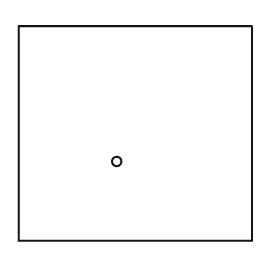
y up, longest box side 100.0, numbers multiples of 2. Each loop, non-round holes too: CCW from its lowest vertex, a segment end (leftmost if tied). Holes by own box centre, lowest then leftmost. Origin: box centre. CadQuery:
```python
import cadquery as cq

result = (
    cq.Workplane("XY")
    .moveTo(-50.0, -46.0)
    .lineTo(50.0, -46.0)
    .lineTo(50.0, 46.0)
    .lineTo(-50.0, 46.0)
    .close()
    .moveTo(-8.0, -12.0)
    .circle(2.0)
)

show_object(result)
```